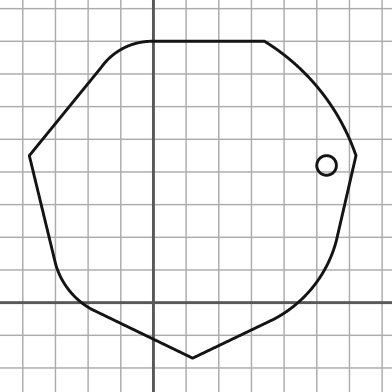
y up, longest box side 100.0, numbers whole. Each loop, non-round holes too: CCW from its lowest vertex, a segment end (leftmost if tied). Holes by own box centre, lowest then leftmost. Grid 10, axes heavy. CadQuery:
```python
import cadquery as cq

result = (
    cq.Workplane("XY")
    .moveTo(12.0, -17.0)
    .lineTo(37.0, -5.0)
    .threePointArc((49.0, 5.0), (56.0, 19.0))
    .lineTo(62.0, 45.0)
    .threePointArc((51.0, 65.0), (34.0, 80.0))
    .lineTo(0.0, 80.0)
    .threePointArc((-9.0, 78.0), (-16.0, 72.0))
    .lineTo(-38.0, 45.0)
    .lineTo(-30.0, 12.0)
    .threePointArc((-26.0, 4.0), (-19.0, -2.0))
    .close()
    .moveTo(53.0, 42.0)
    .circle(3.0)
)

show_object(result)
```